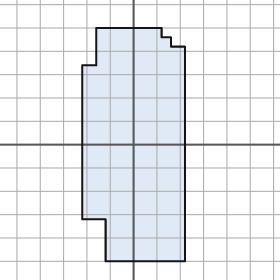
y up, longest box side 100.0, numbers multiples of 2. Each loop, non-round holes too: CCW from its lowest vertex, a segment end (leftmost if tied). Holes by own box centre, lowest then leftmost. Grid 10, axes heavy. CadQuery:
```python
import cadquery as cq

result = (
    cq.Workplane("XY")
    .moveTo(-12.0, -50.0)
    .lineTo(22.0, -50.0)
    .lineTo(22.0, 42.0)
    .lineTo(16.0, 42.0)
    .lineTo(16.0, 46.0)
    .lineTo(12.0, 46.0)
    .lineTo(12.0, 50.0)
    .lineTo(-16.0, 50.0)
    .lineTo(-16.0, 34.0)
    .lineTo(-22.0, 34.0)
    .lineTo(-22.0, -32.0)
    .lineTo(-12.0, -32.0)
    .close()
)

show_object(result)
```